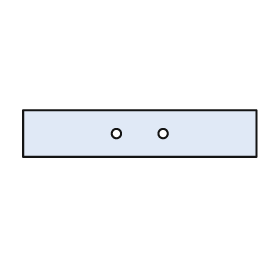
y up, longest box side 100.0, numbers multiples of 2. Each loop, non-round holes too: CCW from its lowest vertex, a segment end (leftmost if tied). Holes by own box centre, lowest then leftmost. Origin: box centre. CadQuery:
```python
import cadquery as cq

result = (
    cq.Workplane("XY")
    .moveTo(-50.0, -10.0)
    .lineTo(50.0, -10.0)
    .lineTo(50.0, 10.0)
    .lineTo(-50.0, 10.0)
    .close()
    .moveTo(-10.0, 0.0)
    .circle(2.0)
    .moveTo(10.0, 0.0)
    .circle(2.0)
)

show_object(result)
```